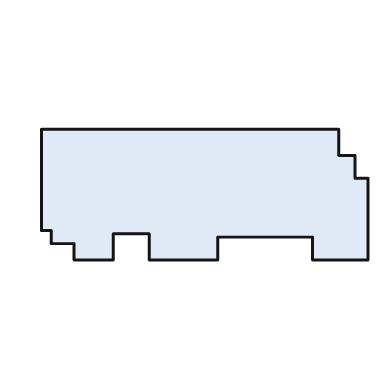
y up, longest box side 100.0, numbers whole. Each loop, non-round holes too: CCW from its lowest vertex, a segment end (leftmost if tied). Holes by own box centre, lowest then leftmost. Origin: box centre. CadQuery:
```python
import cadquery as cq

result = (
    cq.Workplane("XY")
    .moveTo(-40.0, -20.0)
    .lineTo(-28.0, -20.0)
    .lineTo(-28.0, -12.0)
    .lineTo(-17.0, -12.0)
    .lineTo(-17.0, -20.0)
    .lineTo(4.0, -20.0)
    .lineTo(4.0, -13.0)
    .lineTo(33.0, -13.0)
    .lineTo(33.0, -20.0)
    .lineTo(50.0, -20.0)
    .lineTo(50.0, 5.0)
    .lineTo(46.0, 5.0)
    .lineTo(46.0, 12.0)
    .lineTo(41.0, 12.0)
    .lineTo(41.0, 20.0)
    .lineTo(-50.0, 20.0)
    .lineTo(-50.0, -11.0)
    .lineTo(-47.0, -11.0)
    .lineTo(-47.0, -15.0)
    .lineTo(-40.0, -15.0)
    .close()
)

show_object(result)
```